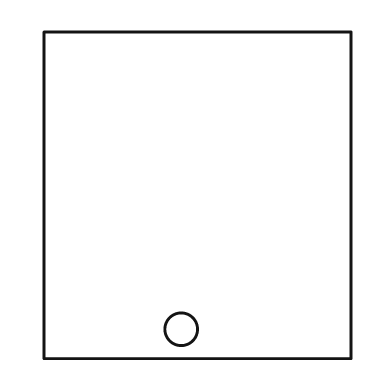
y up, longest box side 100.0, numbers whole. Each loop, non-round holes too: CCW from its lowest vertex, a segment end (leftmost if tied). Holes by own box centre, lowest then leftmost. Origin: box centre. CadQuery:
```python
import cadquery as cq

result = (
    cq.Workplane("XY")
    .moveTo(-47.0, -50.0)
    .lineTo(47.0, -50.0)
    .lineTo(47.0, 50.0)
    .lineTo(-47.0, 50.0)
    .close()
    .moveTo(-5.0, -41.0)
    .circle(5.0)
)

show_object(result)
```